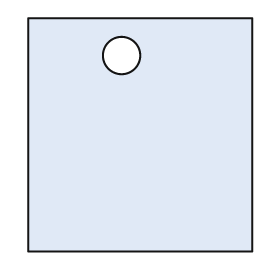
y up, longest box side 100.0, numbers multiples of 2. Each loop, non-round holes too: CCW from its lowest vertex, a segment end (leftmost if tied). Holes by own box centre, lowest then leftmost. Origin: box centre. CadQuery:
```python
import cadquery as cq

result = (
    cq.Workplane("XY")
    .moveTo(-48.0, -50.0)
    .lineTo(48.0, -50.0)
    .lineTo(48.0, 50.0)
    .lineTo(-48.0, 50.0)
    .close()
    .moveTo(-8.0, 34.0)
    .circle(8.0)
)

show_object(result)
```